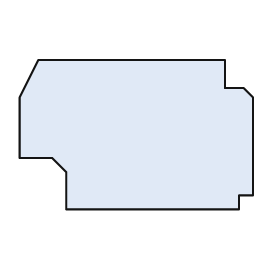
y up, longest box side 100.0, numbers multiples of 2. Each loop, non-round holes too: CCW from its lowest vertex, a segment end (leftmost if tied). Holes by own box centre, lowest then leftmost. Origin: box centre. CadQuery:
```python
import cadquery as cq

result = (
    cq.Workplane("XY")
    .moveTo(-30.0, -32.0)
    .lineTo(44.0, -32.0)
    .lineTo(44.0, -26.0)
    .lineTo(50.0, -26.0)
    .lineTo(50.0, 16.0)
    .lineTo(46.0, 20.0)
    .lineTo(38.0, 20.0)
    .lineTo(38.0, 32.0)
    .lineTo(-42.0, 32.0)
    .lineTo(-50.0, 16.0)
    .lineTo(-50.0, -10.0)
    .lineTo(-36.0, -10.0)
    .lineTo(-30.0, -16.0)
    .close()
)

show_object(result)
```